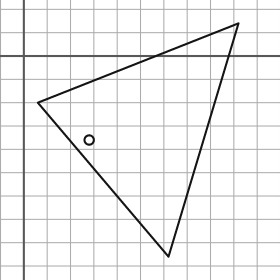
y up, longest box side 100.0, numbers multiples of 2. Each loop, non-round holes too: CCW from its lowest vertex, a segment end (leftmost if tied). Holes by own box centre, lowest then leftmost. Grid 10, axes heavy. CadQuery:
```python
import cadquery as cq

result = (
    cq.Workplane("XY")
    .moveTo(62.0, -86.0)
    .lineTo(92.0, 14.0)
    .lineTo(6.0, -20.0)
    .close()
    .moveTo(28.0, -36.0)
    .circle(2.0)
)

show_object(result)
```